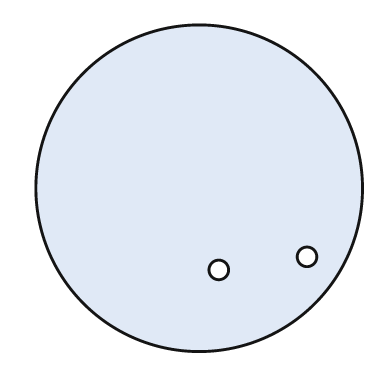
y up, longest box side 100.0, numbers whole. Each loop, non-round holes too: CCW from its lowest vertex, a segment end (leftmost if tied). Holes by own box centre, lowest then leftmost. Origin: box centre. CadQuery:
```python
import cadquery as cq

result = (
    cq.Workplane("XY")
    .moveTo(0.0, 0.0)
    .circle(50.0)
    .moveTo(6.0, -25.0)
    .circle(3.0)
    .moveTo(33.0, -21.0)
    .circle(3.0)
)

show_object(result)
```